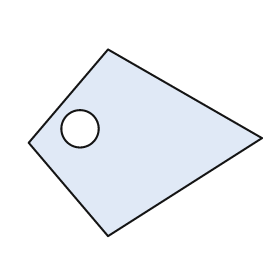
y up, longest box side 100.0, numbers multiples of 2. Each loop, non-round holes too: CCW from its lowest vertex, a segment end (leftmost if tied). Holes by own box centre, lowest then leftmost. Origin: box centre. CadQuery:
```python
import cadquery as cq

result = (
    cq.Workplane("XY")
    .moveTo(-16.0, -40.0)
    .lineTo(50.0, 2.0)
    .lineTo(-16.0, 40.0)
    .lineTo(-50.0, 0.0)
    .close()
    .moveTo(-28.0, 6.0)
    .circle(8.0)
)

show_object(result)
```